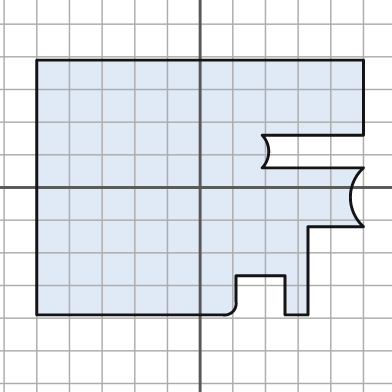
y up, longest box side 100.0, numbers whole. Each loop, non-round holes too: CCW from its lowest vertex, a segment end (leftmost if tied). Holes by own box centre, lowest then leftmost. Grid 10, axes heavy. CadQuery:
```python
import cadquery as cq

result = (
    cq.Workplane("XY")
    .moveTo(-50.0, -39.0)
    .lineTo(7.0, -39.0)
    .threePointArc((10.0, -38.0), (11.0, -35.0))
    .lineTo(11.0, -27.0)
    .lineTo(26.0, -27.0)
    .lineTo(26.0, -39.0)
    .lineTo(33.0, -39.0)
    .lineTo(33.0, -12.0)
    .lineTo(50.0, -12.0)
    .threePointArc((46.0, -3.0), (50.0, 6.0))
    .lineTo(19.0, 6.0)
    .threePointArc((21.0, 11.0), (19.0, 16.0))
    .lineTo(50.0, 16.0)
    .lineTo(50.0, 39.0)
    .lineTo(-50.0, 39.0)
    .close()
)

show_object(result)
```